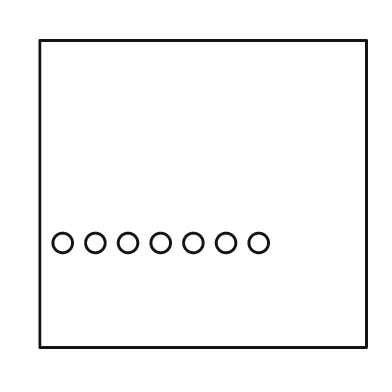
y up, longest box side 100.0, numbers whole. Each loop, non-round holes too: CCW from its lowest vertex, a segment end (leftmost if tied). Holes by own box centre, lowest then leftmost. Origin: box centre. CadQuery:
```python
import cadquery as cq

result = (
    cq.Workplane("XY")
    .moveTo(-50.0, -47.0)
    .lineTo(50.0, -47.0)
    .lineTo(50.0, 47.0)
    .lineTo(-50.0, 47.0)
    .close()
    .moveTo(-43.0, -15.0)
    .circle(3.0)
    .moveTo(-33.0, -15.0)
    .circle(3.0)
    .moveTo(-23.0, -15.0)
    .circle(3.0)
    .moveTo(-13.0, -15.0)
    .circle(3.0)
    .moveTo(-3.0, -15.0)
    .circle(3.0)
    .moveTo(7.0, -15.0)
    .circle(3.0)
    .moveTo(17.0, -15.0)
    .circle(3.0)
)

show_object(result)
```